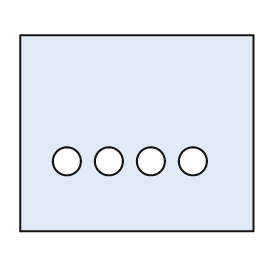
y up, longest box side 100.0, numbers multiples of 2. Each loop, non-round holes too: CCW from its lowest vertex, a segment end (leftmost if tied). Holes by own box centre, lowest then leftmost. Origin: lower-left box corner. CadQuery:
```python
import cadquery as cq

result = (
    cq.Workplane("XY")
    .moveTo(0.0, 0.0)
    .lineTo(100.0, 0.0)
    .lineTo(100.0, 84.0)
    .lineTo(0.0, 84.0)
    .close()
    .moveTo(20.0, 30.0)
    .circle(6.0)
    .moveTo(38.0, 30.0)
    .circle(6.0)
    .moveTo(56.0, 30.0)
    .circle(6.0)
    .moveTo(74.0, 30.0)
    .circle(6.0)
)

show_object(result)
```